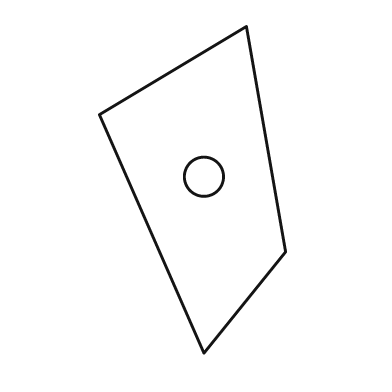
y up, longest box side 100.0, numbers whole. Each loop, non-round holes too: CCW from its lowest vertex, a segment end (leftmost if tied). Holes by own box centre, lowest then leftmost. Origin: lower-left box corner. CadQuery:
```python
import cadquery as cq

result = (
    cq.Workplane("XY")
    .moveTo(32.0, 0.0)
    .lineTo(57.0, 31.0)
    .lineTo(45.0, 100.0)
    .lineTo(0.0, 73.0)
    .close()
    .moveTo(32.0, 54.0)
    .circle(6.0)
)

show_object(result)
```